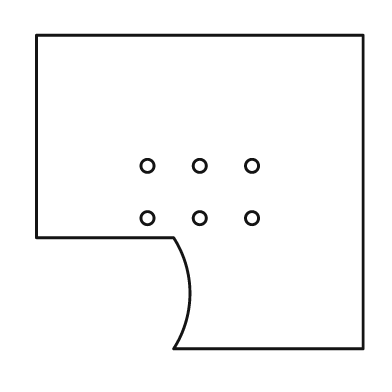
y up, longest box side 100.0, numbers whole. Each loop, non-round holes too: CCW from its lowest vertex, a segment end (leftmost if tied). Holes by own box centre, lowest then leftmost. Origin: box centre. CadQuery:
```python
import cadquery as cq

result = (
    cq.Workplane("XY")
    .moveTo(-8.0, -48.0)
    .lineTo(50.0, -48.0)
    .lineTo(50.0, 48.0)
    .lineTo(-50.0, 48.0)
    .lineTo(-50.0, -14.0)
    .lineTo(-8.0, -14.0)
    .threePointArc((-3.0, -31.0), (-8.0, -48.0))
    .close()
    .moveTo(-16.0, -8.0)
    .circle(2.0)
    .moveTo(0.0, -8.0)
    .circle(2.0)
    .moveTo(16.0, -8.0)
    .circle(2.0)
    .moveTo(-16.0, 8.0)
    .circle(2.0)
    .moveTo(0.0, 8.0)
    .circle(2.0)
    .moveTo(16.0, 8.0)
    .circle(2.0)
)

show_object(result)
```